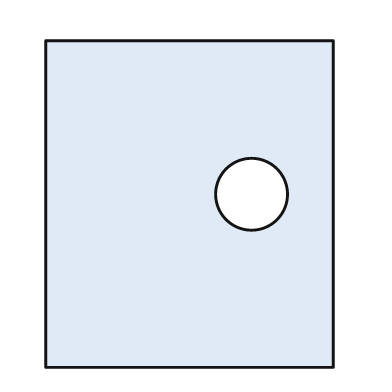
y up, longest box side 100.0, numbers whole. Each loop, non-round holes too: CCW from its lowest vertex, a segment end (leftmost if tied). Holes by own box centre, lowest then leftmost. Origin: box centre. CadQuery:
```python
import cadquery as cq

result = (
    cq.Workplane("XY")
    .moveTo(-44.0, -50.0)
    .lineTo(44.0, -50.0)
    .lineTo(44.0, 50.0)
    .lineTo(-44.0, 50.0)
    .close()
    .moveTo(19.0, 3.0)
    .circle(11.0)
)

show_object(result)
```